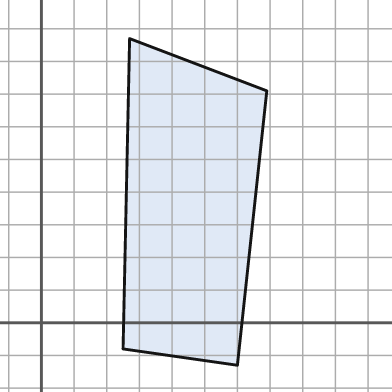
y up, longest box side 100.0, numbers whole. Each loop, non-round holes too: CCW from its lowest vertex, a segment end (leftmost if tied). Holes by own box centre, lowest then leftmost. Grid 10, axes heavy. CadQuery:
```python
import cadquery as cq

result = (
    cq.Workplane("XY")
    .moveTo(60.0, -13.0)
    .lineTo(69.0, 71.0)
    .lineTo(27.0, 87.0)
    .lineTo(25.0, -8.0)
    .close()
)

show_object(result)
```